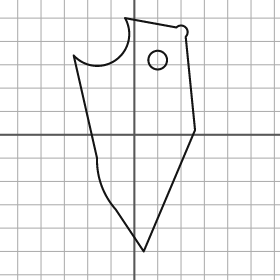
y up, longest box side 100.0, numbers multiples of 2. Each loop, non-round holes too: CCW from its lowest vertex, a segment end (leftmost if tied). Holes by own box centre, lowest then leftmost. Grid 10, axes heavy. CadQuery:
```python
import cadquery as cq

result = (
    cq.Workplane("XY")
    .moveTo(4.0, -50.0)
    .lineTo(26.0, 2.0)
    .lineTo(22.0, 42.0)
    .threePointArc((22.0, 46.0), (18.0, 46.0))
    .lineTo(-4.0, 50.0)
    .threePointArc((-8.0, 32.0), (-26.0, 34.0))
    .lineTo(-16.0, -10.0)
    .threePointArc((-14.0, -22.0), (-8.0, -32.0))
    .close()
    .moveTo(10.0, 32.0)
    .circle(4.0)
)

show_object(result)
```